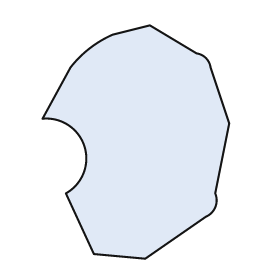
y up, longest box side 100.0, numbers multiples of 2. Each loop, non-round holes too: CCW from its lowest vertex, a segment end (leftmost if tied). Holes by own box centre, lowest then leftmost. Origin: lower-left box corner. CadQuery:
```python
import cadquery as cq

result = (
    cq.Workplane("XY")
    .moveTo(44.0, 0.0)
    .lineTo(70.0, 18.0)
    .threePointArc((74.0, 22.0), (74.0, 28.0))
    .lineTo(80.0, 58.0)
    .lineTo(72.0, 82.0)
    .threePointArc((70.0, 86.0), (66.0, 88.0))
    .lineTo(46.0, 100.0)
    .lineTo(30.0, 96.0)
    .threePointArc((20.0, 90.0), (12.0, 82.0))
    .lineTo(0.0, 60.0)
    .threePointArc((18.0, 48.0), (10.0, 28.0))
    .lineTo(22.0, 2.0)
    .close()
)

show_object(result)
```